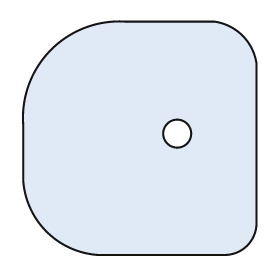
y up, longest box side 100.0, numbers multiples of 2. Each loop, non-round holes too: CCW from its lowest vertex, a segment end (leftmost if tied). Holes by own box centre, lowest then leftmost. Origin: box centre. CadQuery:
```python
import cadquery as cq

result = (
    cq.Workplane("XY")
    .moveTo(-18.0, -50.0)
    .lineTo(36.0, -50.0)
    .threePointArc((46.0, -46.0), (50.0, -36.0))
    .lineTo(50.0, 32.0)
    .threePointArc((44.0, 44.0), (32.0, 50.0))
    .lineTo(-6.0, 50.0)
    .threePointArc((-38.0, 38.0), (-50.0, 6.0))
    .lineTo(-50.0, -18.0)
    .threePointArc((-40.0, -40.0), (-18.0, -50.0))
    .close()
    .moveTo(16.0, 2.0)
    .circle(6.0)
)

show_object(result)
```